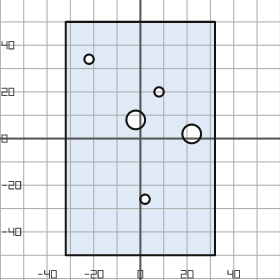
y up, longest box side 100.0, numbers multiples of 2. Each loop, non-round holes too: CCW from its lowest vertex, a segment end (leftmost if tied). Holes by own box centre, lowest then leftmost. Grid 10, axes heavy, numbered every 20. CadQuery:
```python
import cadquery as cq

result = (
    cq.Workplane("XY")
    .moveTo(-32.0, -50.0)
    .lineTo(32.0, -50.0)
    .lineTo(32.0, 50.0)
    .lineTo(-32.0, 50.0)
    .close()
    .moveTo(2.0, -26.0)
    .circle(2.0)
    .moveTo(22.0, 2.0)
    .circle(4.0)
    .moveTo(-2.0, 8.0)
    .circle(4.0)
    .moveTo(8.0, 20.0)
    .circle(2.0)
    .moveTo(-22.0, 34.0)
    .circle(2.0)
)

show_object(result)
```